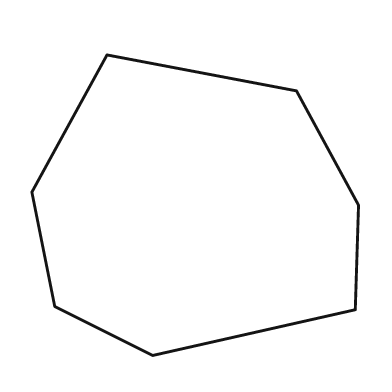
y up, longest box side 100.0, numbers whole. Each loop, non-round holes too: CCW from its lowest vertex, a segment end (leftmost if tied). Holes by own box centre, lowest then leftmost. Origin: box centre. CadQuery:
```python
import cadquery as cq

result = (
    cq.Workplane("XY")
    .moveTo(-13.0, -46.0)
    .lineTo(49.0, -32.0)
    .lineTo(50.0, 0.0)
    .lineTo(31.0, 35.0)
    .lineTo(-27.0, 46.0)
    .lineTo(-50.0, 4.0)
    .lineTo(-43.0, -31.0)
    .close()
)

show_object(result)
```